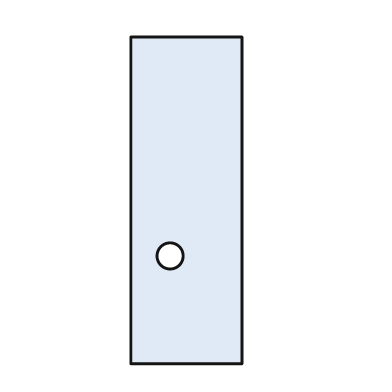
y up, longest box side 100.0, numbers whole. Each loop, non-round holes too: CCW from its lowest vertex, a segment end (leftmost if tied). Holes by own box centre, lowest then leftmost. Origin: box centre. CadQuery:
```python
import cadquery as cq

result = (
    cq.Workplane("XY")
    .moveTo(-17.0, -50.0)
    .lineTo(17.0, -50.0)
    .lineTo(17.0, 50.0)
    .lineTo(-17.0, 50.0)
    .close()
    .moveTo(-5.0, -17.0)
    .circle(4.0)
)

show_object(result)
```